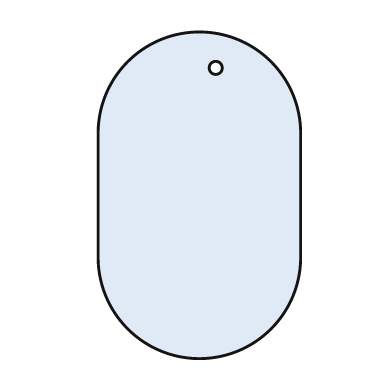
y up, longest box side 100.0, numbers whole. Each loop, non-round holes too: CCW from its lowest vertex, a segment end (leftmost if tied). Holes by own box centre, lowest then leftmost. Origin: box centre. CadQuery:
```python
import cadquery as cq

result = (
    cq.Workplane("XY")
    .moveTo(-31.0, -19.0)
    .threePointArc((0.0, -50.0), (31.0, -19.0))
    .lineTo(31.0, 19.0)
    .threePointArc((0.0, 50.0), (-31.0, 19.0))
    .close()
    .moveTo(5.0, 39.0)
    .circle(2.0)
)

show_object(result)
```